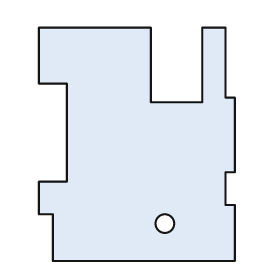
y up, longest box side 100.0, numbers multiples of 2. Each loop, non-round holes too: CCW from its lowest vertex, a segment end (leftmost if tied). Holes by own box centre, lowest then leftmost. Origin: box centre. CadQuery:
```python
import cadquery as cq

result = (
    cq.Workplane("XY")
    .moveTo(-36.0, -50.0)
    .lineTo(42.0, -50.0)
    .lineTo(42.0, -26.0)
    .lineTo(38.0, -26.0)
    .lineTo(38.0, -12.0)
    .lineTo(42.0, -12.0)
    .lineTo(42.0, 20.0)
    .lineTo(38.0, 20.0)
    .lineTo(38.0, 50.0)
    .lineTo(28.0, 50.0)
    .lineTo(28.0, 18.0)
    .lineTo(6.0, 18.0)
    .lineTo(6.0, 50.0)
    .lineTo(-42.0, 50.0)
    .lineTo(-42.0, 26.0)
    .lineTo(-30.0, 26.0)
    .lineTo(-30.0, -16.0)
    .lineTo(-42.0, -16.0)
    .lineTo(-42.0, -30.0)
    .lineTo(-36.0, -30.0)
    .close()
    .moveTo(12.0, -34.0)
    .circle(4.0)
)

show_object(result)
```